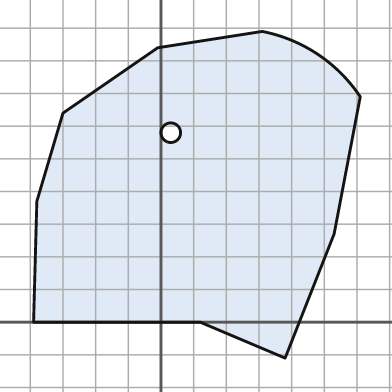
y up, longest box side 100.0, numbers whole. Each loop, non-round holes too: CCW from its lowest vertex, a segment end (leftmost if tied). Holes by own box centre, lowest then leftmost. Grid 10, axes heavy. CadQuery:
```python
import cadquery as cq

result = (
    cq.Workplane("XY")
    .moveTo(38.0, -11.0)
    .lineTo(53.0, 27.0)
    .lineTo(61.0, 69.0)
    .threePointArc((48.0, 82.0), (31.0, 89.0))
    .lineTo(-1.0, 84.0)
    .lineTo(-30.0, 64.0)
    .lineTo(-38.0, 37.0)
    .lineTo(-39.0, 0.0)
    .lineTo(12.0, 0.0)
    .close()
    .moveTo(3.0, 58.0)
    .circle(3.0)
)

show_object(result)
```